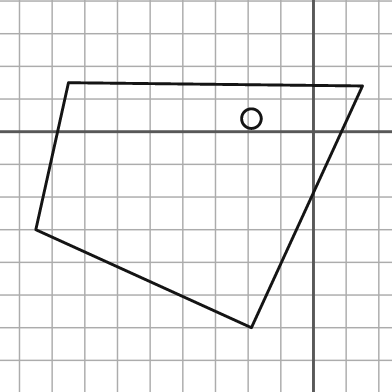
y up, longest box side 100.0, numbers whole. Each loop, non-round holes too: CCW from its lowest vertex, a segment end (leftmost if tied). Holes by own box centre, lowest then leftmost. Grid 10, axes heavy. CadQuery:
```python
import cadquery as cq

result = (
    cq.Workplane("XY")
    .moveTo(-19.0, -60.0)
    .lineTo(15.0, 14.0)
    .lineTo(-75.0, 15.0)
    .lineTo(-85.0, -30.0)
    .close()
    .moveTo(-19.0, 4.0)
    .circle(3.0)
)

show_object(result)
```